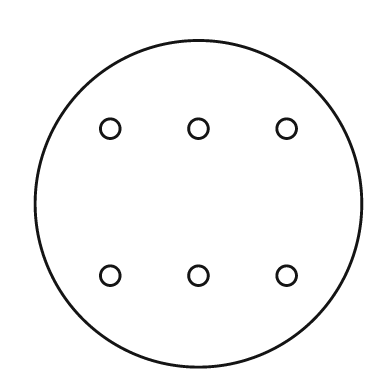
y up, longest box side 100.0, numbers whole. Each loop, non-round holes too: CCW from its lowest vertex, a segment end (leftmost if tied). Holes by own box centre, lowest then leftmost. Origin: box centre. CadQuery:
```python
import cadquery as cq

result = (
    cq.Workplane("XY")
    .moveTo(0.0, 0.0)
    .circle(50.0)
    .moveTo(-27.0, -22.0)
    .circle(3.0)
    .moveTo(0.0, -22.0)
    .circle(3.0)
    .moveTo(27.0, -22.0)
    .circle(3.0)
    .moveTo(-27.0, 23.0)
    .circle(3.0)
    .moveTo(0.0, 23.0)
    .circle(3.0)
    .moveTo(27.0, 23.0)
    .circle(3.0)
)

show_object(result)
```